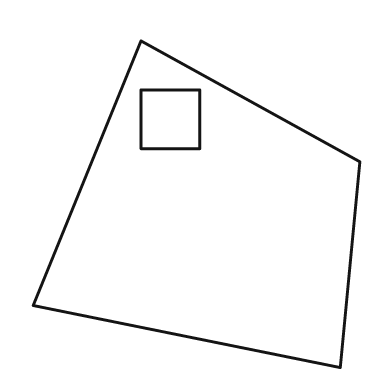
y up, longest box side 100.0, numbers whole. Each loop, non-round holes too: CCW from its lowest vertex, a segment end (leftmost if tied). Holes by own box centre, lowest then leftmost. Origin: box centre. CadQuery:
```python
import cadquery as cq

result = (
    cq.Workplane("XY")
    .moveTo(44.0, -50.0)
    .lineTo(50.0, 13.0)
    .lineTo(-17.0, 50.0)
    .lineTo(-50.0, -31.0)
    .close()
    .moveTo(-17.0, 17.0)
    .lineTo(1.0, 17.0)
    .lineTo(1.0, 35.0)
    .lineTo(-17.0, 35.0)
    .close()
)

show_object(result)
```